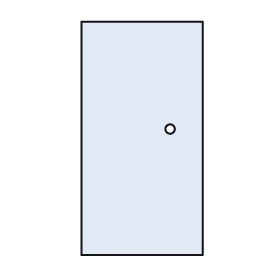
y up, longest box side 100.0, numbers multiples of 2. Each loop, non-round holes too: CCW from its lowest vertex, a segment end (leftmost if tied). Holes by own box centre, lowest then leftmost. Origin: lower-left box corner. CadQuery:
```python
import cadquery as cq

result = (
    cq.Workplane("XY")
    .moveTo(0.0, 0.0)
    .lineTo(52.0, 0.0)
    .lineTo(52.0, 100.0)
    .lineTo(0.0, 100.0)
    .close()
    .moveTo(38.0, 54.0)
    .circle(2.0)
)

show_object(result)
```